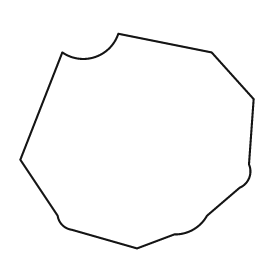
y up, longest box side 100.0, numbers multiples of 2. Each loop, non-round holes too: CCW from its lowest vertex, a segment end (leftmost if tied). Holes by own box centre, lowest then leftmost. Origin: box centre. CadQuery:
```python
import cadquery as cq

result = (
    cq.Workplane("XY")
    .moveTo(0.0, -46.0)
    .lineTo(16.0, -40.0)
    .threePointArc((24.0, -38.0), (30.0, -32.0))
    .lineTo(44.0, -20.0)
    .threePointArc((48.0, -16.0), (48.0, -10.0))
    .lineTo(50.0, 18.0)
    .lineTo(32.0, 38.0)
    .lineTo(-8.0, 46.0)
    .threePointArc((-18.0, 36.0), (-32.0, 38.0))
    .lineTo(-50.0, -8.0)
    .lineTo(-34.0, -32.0)
    .threePointArc((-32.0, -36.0), (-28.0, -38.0))
    .close()
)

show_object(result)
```